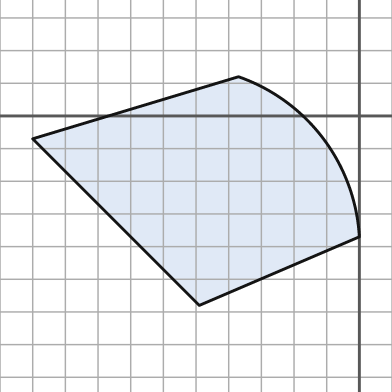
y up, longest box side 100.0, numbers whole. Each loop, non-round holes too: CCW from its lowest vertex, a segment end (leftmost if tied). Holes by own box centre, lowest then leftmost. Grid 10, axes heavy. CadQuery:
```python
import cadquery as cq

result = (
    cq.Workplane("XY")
    .moveTo(-49.0, -58.0)
    .lineTo(0.0, -37.0)
    .threePointArc((-11.0, -7.0), (-37.0, 12.0))
    .lineTo(-100.0, -7.0)
    .close()
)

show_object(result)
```